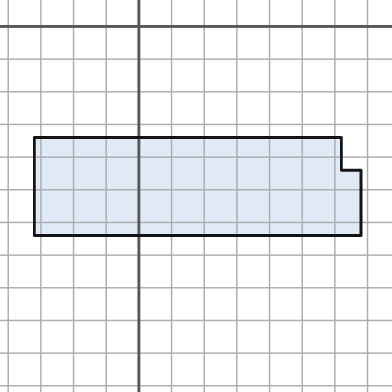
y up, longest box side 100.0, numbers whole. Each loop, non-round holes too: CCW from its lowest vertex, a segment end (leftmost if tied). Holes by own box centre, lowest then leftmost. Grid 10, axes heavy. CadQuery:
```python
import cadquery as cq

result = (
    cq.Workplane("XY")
    .moveTo(-32.0, -64.0)
    .lineTo(68.0, -64.0)
    .lineTo(68.0, -44.0)
    .lineTo(62.0, -44.0)
    .lineTo(62.0, -34.0)
    .lineTo(-32.0, -34.0)
    .close()
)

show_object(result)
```